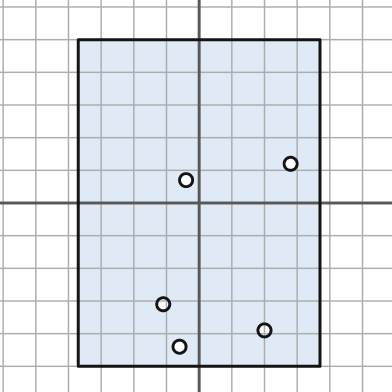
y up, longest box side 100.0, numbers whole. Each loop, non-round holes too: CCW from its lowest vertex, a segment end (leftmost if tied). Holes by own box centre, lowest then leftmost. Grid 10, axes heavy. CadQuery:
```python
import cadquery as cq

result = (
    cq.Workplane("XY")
    .moveTo(-37.0, -50.0)
    .lineTo(37.0, -50.0)
    .lineTo(37.0, 50.0)
    .lineTo(-37.0, 50.0)
    .close()
    .moveTo(-6.0, -44.0)
    .circle(2.0)
    .moveTo(20.0, -39.0)
    .circle(2.0)
    .moveTo(-11.0, -31.0)
    .circle(2.0)
    .moveTo(-4.0, 7.0)
    .circle(2.0)
    .moveTo(28.0, 12.0)
    .circle(2.0)
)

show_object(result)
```